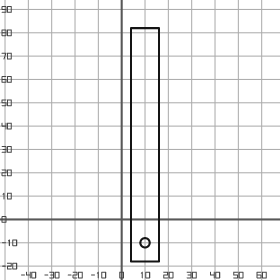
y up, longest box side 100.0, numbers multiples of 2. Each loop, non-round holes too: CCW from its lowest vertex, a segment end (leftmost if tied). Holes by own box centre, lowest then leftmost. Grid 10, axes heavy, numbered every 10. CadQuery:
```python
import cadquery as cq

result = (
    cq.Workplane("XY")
    .moveTo(4.0, -18.0)
    .lineTo(16.0, -18.0)
    .lineTo(16.0, 82.0)
    .lineTo(4.0, 82.0)
    .close()
    .moveTo(10.0, -10.0)
    .circle(2.0)
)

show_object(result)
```